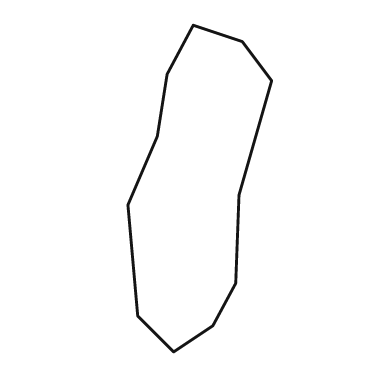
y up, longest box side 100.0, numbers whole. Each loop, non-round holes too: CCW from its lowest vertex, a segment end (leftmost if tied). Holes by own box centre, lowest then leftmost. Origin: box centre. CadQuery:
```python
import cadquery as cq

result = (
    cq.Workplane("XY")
    .moveTo(-8.0, -50.0)
    .lineTo(4.0, -42.0)
    .lineTo(11.0, -29.0)
    .lineTo(12.0, -2.0)
    .lineTo(22.0, 33.0)
    .lineTo(13.0, 45.0)
    .lineTo(-2.0, 50.0)
    .lineTo(-10.0, 35.0)
    .lineTo(-13.0, 16.0)
    .lineTo(-22.0, -5.0)
    .lineTo(-19.0, -39.0)
    .close()
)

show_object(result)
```